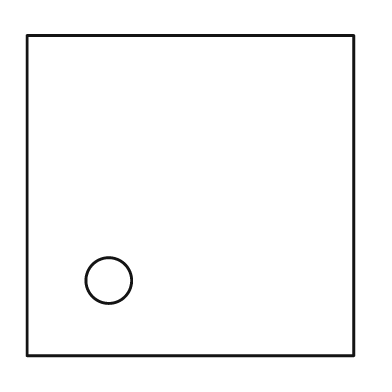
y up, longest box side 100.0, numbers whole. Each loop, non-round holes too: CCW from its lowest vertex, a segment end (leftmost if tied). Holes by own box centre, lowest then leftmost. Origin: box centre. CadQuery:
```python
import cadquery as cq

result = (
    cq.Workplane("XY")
    .moveTo(-50.0, -49.0)
    .lineTo(50.0, -49.0)
    .lineTo(50.0, 49.0)
    .lineTo(-50.0, 49.0)
    .close()
    .moveTo(-25.0, -26.0)
    .circle(7.0)
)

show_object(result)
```